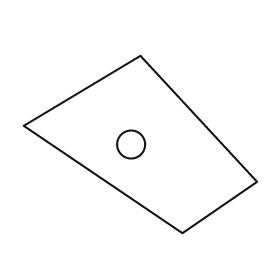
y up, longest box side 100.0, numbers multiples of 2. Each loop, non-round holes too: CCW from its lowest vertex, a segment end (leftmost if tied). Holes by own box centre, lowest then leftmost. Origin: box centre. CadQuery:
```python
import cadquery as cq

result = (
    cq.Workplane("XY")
    .moveTo(18.0, -38.0)
    .lineTo(50.0, -16.0)
    .lineTo(0.0, 38.0)
    .lineTo(-50.0, 8.0)
    .close()
    .moveTo(-4.0, 0.0)
    .circle(6.0)
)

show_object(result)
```